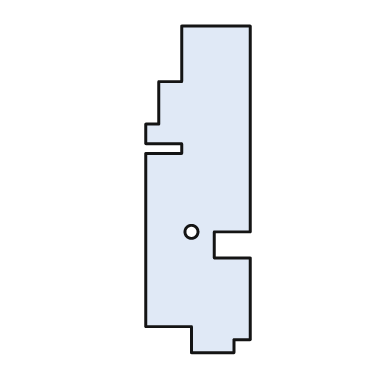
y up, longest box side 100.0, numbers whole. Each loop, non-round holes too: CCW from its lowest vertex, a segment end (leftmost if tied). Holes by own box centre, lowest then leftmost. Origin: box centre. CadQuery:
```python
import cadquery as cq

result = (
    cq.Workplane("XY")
    .moveTo(-2.0, -50.0)
    .lineTo(11.0, -50.0)
    .lineTo(11.0, -46.0)
    .lineTo(16.0, -46.0)
    .lineTo(16.0, -21.0)
    .lineTo(5.0, -21.0)
    .lineTo(5.0, -13.0)
    .lineTo(16.0, -13.0)
    .lineTo(16.0, 50.0)
    .lineTo(-5.0, 50.0)
    .lineTo(-5.0, 33.0)
    .lineTo(-12.0, 33.0)
    .lineTo(-12.0, 20.0)
    .lineTo(-16.0, 20.0)
    .lineTo(-16.0, 14.0)
    .lineTo(-5.0, 14.0)
    .lineTo(-5.0, 11.0)
    .lineTo(-16.0, 11.0)
    .lineTo(-16.0, -42.0)
    .lineTo(-2.0, -42.0)
    .close()
    .moveTo(-2.0, -13.0)
    .circle(2.0)
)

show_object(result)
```